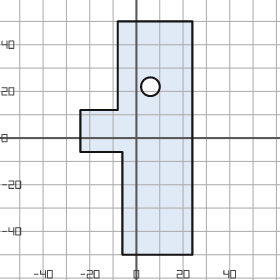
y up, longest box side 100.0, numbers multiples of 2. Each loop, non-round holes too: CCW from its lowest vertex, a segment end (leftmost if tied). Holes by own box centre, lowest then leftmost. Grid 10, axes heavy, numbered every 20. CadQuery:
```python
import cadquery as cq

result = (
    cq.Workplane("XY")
    .moveTo(-6.0, -50.0)
    .lineTo(24.0, -50.0)
    .lineTo(24.0, 50.0)
    .lineTo(-8.0, 50.0)
    .lineTo(-8.0, 12.0)
    .lineTo(-24.0, 12.0)
    .lineTo(-24.0, -6.0)
    .lineTo(-6.0, -6.0)
    .close()
    .moveTo(6.0, 22.0)
    .circle(4.0)
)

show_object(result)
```